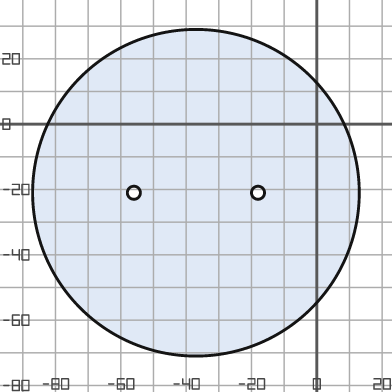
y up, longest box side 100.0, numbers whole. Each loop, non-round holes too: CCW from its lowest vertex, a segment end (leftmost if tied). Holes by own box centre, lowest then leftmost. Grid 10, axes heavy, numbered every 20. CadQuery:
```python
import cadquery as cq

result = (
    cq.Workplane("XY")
    .moveTo(-37.0, -21.0)
    .circle(50.0)
    .moveTo(-56.0, -21.0)
    .circle(2.0)
    .moveTo(-18.0, -21.0)
    .circle(2.0)
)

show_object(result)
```